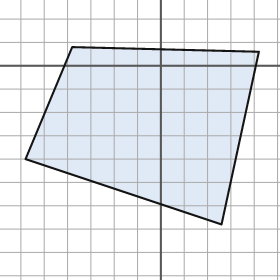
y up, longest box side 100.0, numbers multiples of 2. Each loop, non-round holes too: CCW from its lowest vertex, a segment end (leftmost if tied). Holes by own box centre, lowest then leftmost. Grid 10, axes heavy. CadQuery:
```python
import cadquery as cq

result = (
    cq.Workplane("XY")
    .moveTo(26.0, -68.0)
    .lineTo(42.0, 6.0)
    .lineTo(-38.0, 8.0)
    .lineTo(-58.0, -40.0)
    .close()
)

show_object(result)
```